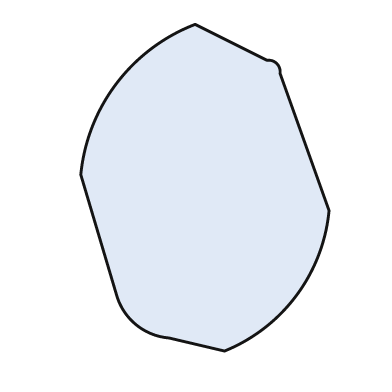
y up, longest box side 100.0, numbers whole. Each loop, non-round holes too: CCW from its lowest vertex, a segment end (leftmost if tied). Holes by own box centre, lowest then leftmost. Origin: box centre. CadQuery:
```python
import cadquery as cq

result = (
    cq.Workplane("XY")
    .moveTo(6.0, -50.0)
    .threePointArc((28.0, -33.0), (38.0, -7.0))
    .lineTo(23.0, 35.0)
    .threePointArc((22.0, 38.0), (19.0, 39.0))
    .lineTo(-3.0, 50.0)
    .threePointArc((-27.0, 32.0), (-38.0, 4.0))
    .lineTo(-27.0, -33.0)
    .threePointArc((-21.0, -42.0), (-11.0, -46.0))
    .close()
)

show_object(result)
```